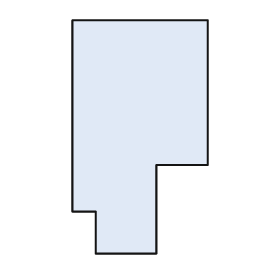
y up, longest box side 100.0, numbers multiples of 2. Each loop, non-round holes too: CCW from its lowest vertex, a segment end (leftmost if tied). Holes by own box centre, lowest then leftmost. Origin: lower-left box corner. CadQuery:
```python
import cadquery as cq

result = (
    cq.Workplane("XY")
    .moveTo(10.0, 0.0)
    .lineTo(36.0, 0.0)
    .lineTo(36.0, 38.0)
    .lineTo(58.0, 38.0)
    .lineTo(58.0, 100.0)
    .lineTo(0.0, 100.0)
    .lineTo(0.0, 18.0)
    .lineTo(10.0, 18.0)
    .close()
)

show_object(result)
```